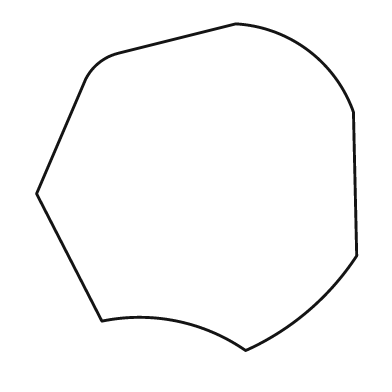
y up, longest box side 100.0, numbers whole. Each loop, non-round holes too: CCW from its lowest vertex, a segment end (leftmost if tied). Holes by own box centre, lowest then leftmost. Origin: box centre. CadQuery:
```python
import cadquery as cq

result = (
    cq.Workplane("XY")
    .moveTo(15.0, -50.0)
    .threePointArc((34.0, -38.0), (49.0, -21.0))
    .lineTo(48.0, 23.0)
    .threePointArc((34.0, 42.0), (12.0, 50.0))
    .lineTo(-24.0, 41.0)
    .threePointArc((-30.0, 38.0), (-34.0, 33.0))
    .lineTo(-49.0, -2.0)
    .lineTo(-29.0, -41.0)
    .threePointArc((-6.0, -41.0), (15.0, -50.0))
    .close()
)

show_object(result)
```